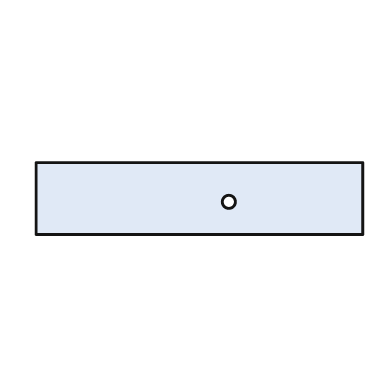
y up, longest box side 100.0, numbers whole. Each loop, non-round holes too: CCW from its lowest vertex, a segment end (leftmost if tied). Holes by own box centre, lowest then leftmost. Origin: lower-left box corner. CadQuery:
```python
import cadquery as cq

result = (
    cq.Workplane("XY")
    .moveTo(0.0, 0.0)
    .lineTo(100.0, 0.0)
    .lineTo(100.0, 22.0)
    .lineTo(0.0, 22.0)
    .close()
    .moveTo(59.0, 10.0)
    .circle(2.0)
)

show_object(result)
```